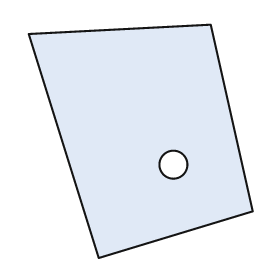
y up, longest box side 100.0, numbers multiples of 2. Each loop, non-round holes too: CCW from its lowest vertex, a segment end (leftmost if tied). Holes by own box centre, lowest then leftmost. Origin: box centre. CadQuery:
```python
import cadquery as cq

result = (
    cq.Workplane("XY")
    .moveTo(-18.0, -50.0)
    .lineTo(48.0, -30.0)
    .lineTo(30.0, 50.0)
    .lineTo(-48.0, 46.0)
    .close()
    .moveTo(14.0, -10.0)
    .circle(6.0)
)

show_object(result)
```